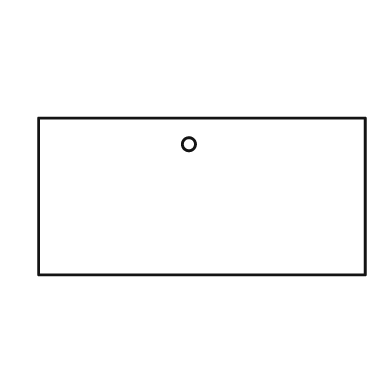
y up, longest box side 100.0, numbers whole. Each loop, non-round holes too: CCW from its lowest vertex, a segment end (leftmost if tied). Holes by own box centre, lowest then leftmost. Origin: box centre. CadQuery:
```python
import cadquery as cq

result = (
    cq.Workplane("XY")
    .moveTo(-50.0, -24.0)
    .lineTo(50.0, -24.0)
    .lineTo(50.0, 24.0)
    .lineTo(-50.0, 24.0)
    .close()
    .moveTo(-4.0, 16.0)
    .circle(2.0)
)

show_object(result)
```